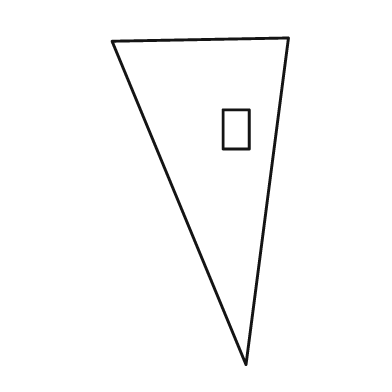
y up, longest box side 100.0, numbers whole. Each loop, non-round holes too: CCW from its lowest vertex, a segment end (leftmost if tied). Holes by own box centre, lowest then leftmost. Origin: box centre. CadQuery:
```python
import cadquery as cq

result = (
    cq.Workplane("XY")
    .moveTo(14.0, -50.0)
    .lineTo(27.0, 50.0)
    .lineTo(-27.0, 49.0)
    .close()
    .moveTo(7.0, 16.0)
    .lineTo(15.0, 16.0)
    .lineTo(15.0, 28.0)
    .lineTo(7.0, 28.0)
    .close()
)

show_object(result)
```